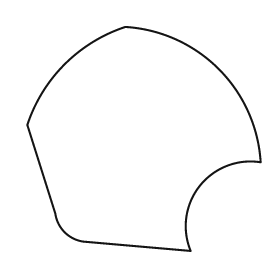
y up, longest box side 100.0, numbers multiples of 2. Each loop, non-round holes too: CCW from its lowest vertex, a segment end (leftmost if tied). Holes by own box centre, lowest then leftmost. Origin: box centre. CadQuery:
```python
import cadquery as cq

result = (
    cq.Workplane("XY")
    .moveTo(20.0, -48.0)
    .threePointArc((24.0, -20.0), (50.0, -10.0))
    .threePointArc((32.0, 30.0), (-8.0, 48.0))
    .threePointArc((-34.0, 32.0), (-50.0, 6.0))
    .lineTo(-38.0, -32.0)
    .threePointArc((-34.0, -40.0), (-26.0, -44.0))
    .close()
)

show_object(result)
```